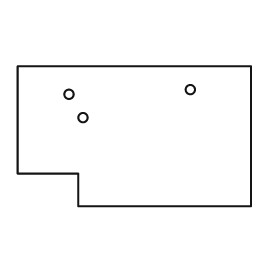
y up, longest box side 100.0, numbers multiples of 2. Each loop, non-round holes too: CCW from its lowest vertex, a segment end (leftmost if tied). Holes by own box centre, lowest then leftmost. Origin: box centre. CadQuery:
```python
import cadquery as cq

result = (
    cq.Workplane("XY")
    .moveTo(-24.0, -30.0)
    .lineTo(50.0, -30.0)
    .lineTo(50.0, 30.0)
    .lineTo(-50.0, 30.0)
    .lineTo(-50.0, -16.0)
    .lineTo(-24.0, -16.0)
    .close()
    .moveTo(-22.0, 8.0)
    .circle(2.0)
    .moveTo(-28.0, 18.0)
    .circle(2.0)
    .moveTo(24.0, 20.0)
    .circle(2.0)
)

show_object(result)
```